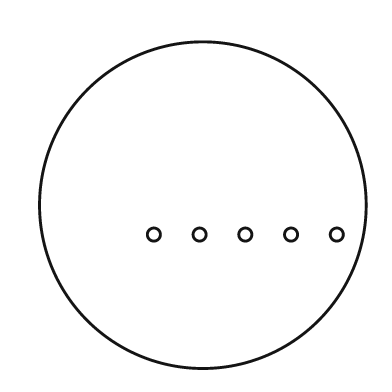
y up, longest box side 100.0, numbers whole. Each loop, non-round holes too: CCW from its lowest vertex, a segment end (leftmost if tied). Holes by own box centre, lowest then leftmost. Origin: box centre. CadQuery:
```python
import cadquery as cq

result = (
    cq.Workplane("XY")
    .moveTo(0.0, 0.0)
    .circle(50.0)
    .moveTo(-15.0, -9.0)
    .circle(2.0)
    .moveTo(-1.0, -9.0)
    .circle(2.0)
    .moveTo(13.0, -9.0)
    .circle(2.0)
    .moveTo(27.0, -9.0)
    .circle(2.0)
    .moveTo(41.0, -9.0)
    .circle(2.0)
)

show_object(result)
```